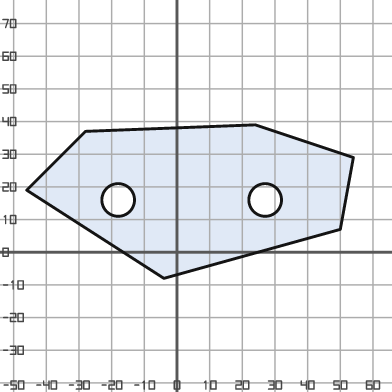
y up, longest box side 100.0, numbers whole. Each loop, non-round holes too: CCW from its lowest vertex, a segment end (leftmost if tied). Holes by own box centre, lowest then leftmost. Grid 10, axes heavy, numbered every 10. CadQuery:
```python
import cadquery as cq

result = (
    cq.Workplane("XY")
    .moveTo(-4.0, -8.0)
    .lineTo(50.0, 7.0)
    .lineTo(54.0, 29.0)
    .lineTo(24.0, 39.0)
    .lineTo(-28.0, 37.0)
    .lineTo(-46.0, 19.0)
    .close()
    .moveTo(-18.0, 16.0)
    .circle(5.0)
    .moveTo(27.0, 16.0)
    .circle(5.0)
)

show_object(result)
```